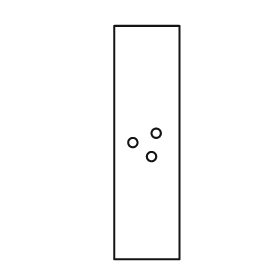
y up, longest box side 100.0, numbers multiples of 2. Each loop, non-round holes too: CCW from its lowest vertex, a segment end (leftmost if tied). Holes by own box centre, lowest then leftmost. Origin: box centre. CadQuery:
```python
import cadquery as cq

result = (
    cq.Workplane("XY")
    .moveTo(-14.0, -50.0)
    .lineTo(14.0, -50.0)
    .lineTo(14.0, 50.0)
    .lineTo(-14.0, 50.0)
    .close()
    .moveTo(2.0, -6.0)
    .circle(2.0)
    .moveTo(-6.0, 0.0)
    .circle(2.0)
    .moveTo(4.0, 4.0)
    .circle(2.0)
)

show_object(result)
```